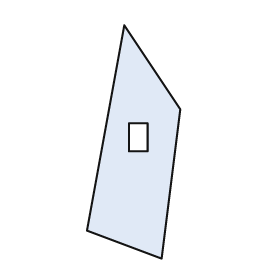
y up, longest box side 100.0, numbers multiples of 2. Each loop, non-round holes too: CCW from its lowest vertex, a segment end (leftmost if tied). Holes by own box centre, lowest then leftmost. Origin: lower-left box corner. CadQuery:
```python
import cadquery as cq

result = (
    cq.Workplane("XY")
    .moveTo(32.0, 0.0)
    .lineTo(40.0, 64.0)
    .lineTo(16.0, 100.0)
    .lineTo(0.0, 12.0)
    .close()
    .moveTo(18.0, 46.0)
    .lineTo(26.0, 46.0)
    .lineTo(26.0, 58.0)
    .lineTo(18.0, 58.0)
    .close()
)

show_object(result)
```